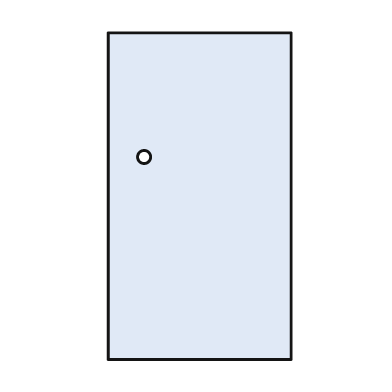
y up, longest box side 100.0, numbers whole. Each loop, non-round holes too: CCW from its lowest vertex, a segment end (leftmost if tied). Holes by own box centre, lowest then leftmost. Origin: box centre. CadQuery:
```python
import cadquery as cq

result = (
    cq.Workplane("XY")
    .moveTo(-28.0, -50.0)
    .lineTo(28.0, -50.0)
    .lineTo(28.0, 50.0)
    .lineTo(-28.0, 50.0)
    .close()
    .moveTo(-17.0, 12.0)
    .circle(2.0)
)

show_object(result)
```